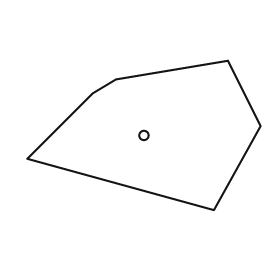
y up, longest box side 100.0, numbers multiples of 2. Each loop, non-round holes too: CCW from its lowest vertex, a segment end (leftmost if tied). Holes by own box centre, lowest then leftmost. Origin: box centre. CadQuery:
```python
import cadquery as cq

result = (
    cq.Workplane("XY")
    .moveTo(30.0, -32.0)
    .lineTo(50.0, 4.0)
    .lineTo(36.0, 32.0)
    .lineTo(-12.0, 24.0)
    .lineTo(-22.0, 18.0)
    .lineTo(-50.0, -10.0)
    .close()
    .moveTo(0.0, 0.0)
    .circle(2.0)
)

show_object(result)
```